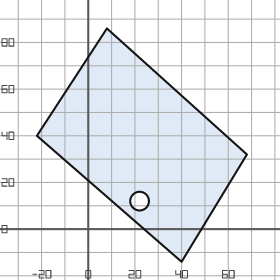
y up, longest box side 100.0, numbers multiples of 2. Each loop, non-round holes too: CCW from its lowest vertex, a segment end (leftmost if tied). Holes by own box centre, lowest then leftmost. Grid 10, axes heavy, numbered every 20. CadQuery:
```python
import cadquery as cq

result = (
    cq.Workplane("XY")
    .moveTo(40.0, -14.0)
    .lineTo(68.0, 32.0)
    .lineTo(8.0, 86.0)
    .lineTo(-22.0, 40.0)
    .close()
    .moveTo(22.0, 12.0)
    .circle(4.0)
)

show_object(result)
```